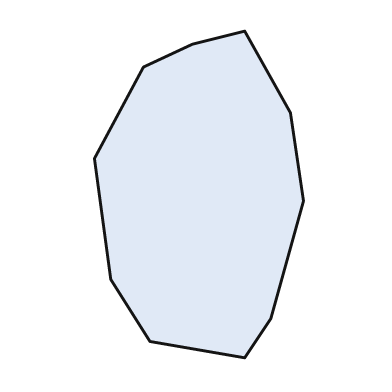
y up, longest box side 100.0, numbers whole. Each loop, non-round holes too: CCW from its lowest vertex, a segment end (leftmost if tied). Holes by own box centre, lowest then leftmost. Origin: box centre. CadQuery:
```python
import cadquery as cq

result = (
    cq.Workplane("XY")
    .moveTo(14.0, -50.0)
    .lineTo(22.0, -38.0)
    .lineTo(32.0, -2.0)
    .lineTo(28.0, 25.0)
    .lineTo(14.0, 50.0)
    .lineTo(-2.0, 46.0)
    .lineTo(-17.0, 39.0)
    .lineTo(-32.0, 11.0)
    .lineTo(-27.0, -26.0)
    .lineTo(-15.0, -45.0)
    .close()
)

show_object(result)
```